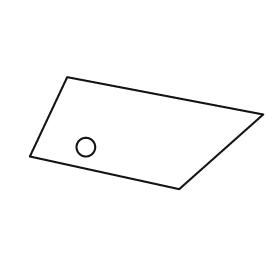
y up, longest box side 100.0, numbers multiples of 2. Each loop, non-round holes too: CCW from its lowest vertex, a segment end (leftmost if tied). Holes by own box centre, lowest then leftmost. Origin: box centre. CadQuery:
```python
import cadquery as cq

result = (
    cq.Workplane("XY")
    .moveTo(14.0, -24.0)
    .lineTo(50.0, 8.0)
    .lineTo(-34.0, 24.0)
    .lineTo(-50.0, -10.0)
    .close()
    .moveTo(-26.0, -6.0)
    .circle(4.0)
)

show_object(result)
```